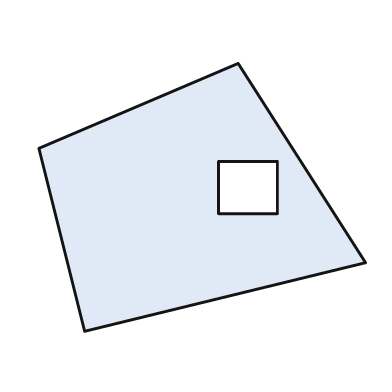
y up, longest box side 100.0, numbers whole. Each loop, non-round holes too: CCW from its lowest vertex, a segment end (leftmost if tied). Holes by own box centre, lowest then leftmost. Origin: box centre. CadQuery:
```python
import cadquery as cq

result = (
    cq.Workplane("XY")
    .moveTo(-36.0, -41.0)
    .lineTo(50.0, -20.0)
    .lineTo(11.0, 41.0)
    .lineTo(-50.0, 15.0)
    .close()
    .moveTo(5.0, -5.0)
    .lineTo(23.0, -5.0)
    .lineTo(23.0, 11.0)
    .lineTo(5.0, 11.0)
    .close()
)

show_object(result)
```